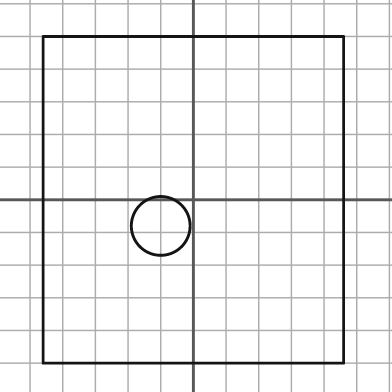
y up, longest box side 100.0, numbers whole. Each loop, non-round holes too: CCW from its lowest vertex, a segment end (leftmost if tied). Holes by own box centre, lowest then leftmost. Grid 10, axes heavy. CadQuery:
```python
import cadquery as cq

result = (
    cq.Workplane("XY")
    .moveTo(-46.0, -50.0)
    .lineTo(46.0, -50.0)
    .lineTo(46.0, 50.0)
    .lineTo(-46.0, 50.0)
    .close()
    .moveTo(-10.0, -8.0)
    .circle(9.0)
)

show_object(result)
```